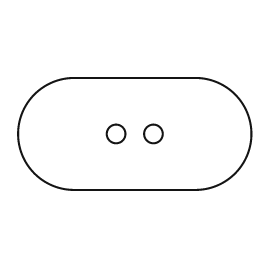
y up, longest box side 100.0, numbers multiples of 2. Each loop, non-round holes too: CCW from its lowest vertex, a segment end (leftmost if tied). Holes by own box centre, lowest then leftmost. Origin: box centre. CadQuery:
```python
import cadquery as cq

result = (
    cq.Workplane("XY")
    .moveTo(-26.0, -24.0)
    .lineTo(26.0, -24.0)
    .threePointArc((50.0, 0.0), (26.0, 24.0))
    .lineTo(-26.0, 24.0)
    .threePointArc((-50.0, 0.0), (-26.0, -24.0))
    .close()
    .moveTo(-8.0, 0.0)
    .circle(4.0)
    .moveTo(8.0, 0.0)
    .circle(4.0)
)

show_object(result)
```